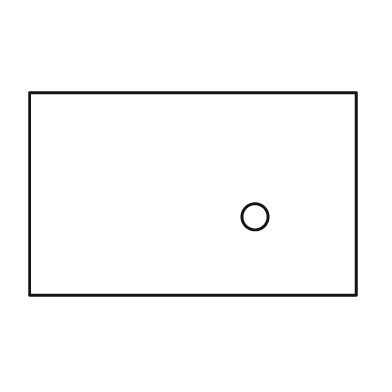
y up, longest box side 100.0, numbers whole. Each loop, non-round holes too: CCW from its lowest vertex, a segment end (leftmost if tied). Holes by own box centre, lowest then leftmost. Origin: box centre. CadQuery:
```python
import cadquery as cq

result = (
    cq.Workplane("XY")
    .moveTo(-50.0, -31.0)
    .lineTo(50.0, -31.0)
    .lineTo(50.0, 31.0)
    .lineTo(-50.0, 31.0)
    .close()
    .moveTo(19.0, -7.0)
    .circle(4.0)
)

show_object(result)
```